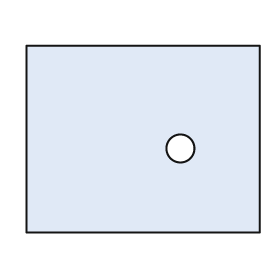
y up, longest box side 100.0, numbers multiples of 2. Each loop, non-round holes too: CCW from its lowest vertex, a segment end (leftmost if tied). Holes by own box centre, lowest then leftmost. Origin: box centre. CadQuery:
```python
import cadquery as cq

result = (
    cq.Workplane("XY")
    .moveTo(-50.0, -40.0)
    .lineTo(50.0, -40.0)
    .lineTo(50.0, 40.0)
    .lineTo(-50.0, 40.0)
    .close()
    .moveTo(16.0, -4.0)
    .circle(6.0)
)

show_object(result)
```